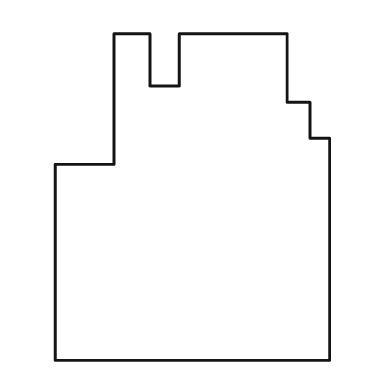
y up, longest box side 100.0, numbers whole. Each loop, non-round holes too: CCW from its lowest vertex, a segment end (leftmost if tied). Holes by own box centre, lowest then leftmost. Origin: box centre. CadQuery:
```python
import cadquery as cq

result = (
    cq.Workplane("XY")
    .moveTo(-42.0, -50.0)
    .lineTo(42.0, -50.0)
    .lineTo(42.0, 18.0)
    .lineTo(36.0, 18.0)
    .lineTo(36.0, 29.0)
    .lineTo(29.0, 29.0)
    .lineTo(29.0, 50.0)
    .lineTo(-4.0, 50.0)
    .lineTo(-4.0, 34.0)
    .lineTo(-13.0, 34.0)
    .lineTo(-13.0, 50.0)
    .lineTo(-24.0, 50.0)
    .lineTo(-24.0, 10.0)
    .lineTo(-42.0, 10.0)
    .close()
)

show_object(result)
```